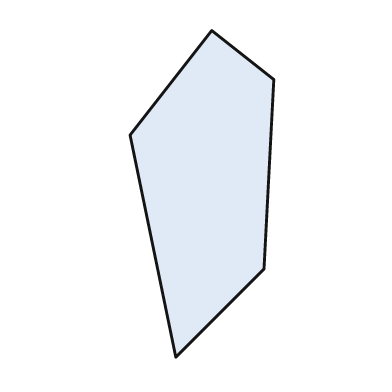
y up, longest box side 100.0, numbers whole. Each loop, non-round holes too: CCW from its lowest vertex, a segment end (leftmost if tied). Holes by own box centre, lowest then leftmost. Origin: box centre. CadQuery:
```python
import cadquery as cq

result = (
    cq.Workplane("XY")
    .moveTo(-8.0, -50.0)
    .lineTo(19.0, -23.0)
    .lineTo(22.0, 35.0)
    .lineTo(3.0, 50.0)
    .lineTo(-22.0, 18.0)
    .close()
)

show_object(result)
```